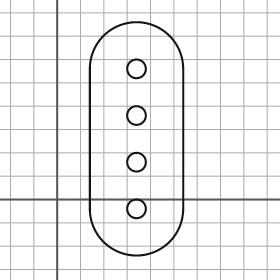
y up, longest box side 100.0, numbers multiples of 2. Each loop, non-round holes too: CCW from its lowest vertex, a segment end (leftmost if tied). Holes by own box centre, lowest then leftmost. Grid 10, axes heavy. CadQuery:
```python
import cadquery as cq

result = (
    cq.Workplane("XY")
    .moveTo(14.0, -4.0)
    .threePointArc((34.0, -24.0), (54.0, -4.0))
    .lineTo(54.0, 56.0)
    .threePointArc((34.0, 76.0), (14.0, 56.0))
    .close()
    .moveTo(34.0, -4.0)
    .circle(4.0)
    .moveTo(34.0, 16.0)
    .circle(4.0)
    .moveTo(34.0, 36.0)
    .circle(4.0)
    .moveTo(34.0, 56.0)
    .circle(4.0)
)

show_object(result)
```